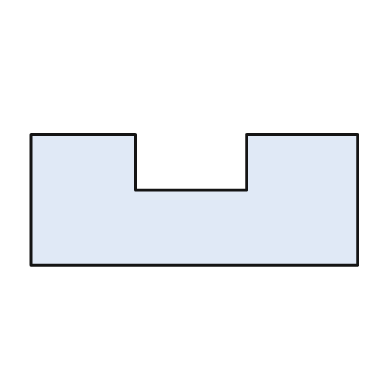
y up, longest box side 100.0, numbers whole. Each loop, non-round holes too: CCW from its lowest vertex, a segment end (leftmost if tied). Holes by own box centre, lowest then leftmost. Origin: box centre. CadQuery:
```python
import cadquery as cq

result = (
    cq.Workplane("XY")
    .moveTo(-50.0, -20.0)
    .lineTo(50.0, -20.0)
    .lineTo(50.0, 20.0)
    .lineTo(16.0, 20.0)
    .lineTo(16.0, 3.0)
    .lineTo(-18.0, 3.0)
    .lineTo(-18.0, 20.0)
    .lineTo(-50.0, 20.0)
    .close()
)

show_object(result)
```